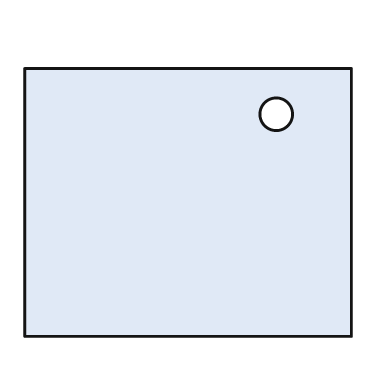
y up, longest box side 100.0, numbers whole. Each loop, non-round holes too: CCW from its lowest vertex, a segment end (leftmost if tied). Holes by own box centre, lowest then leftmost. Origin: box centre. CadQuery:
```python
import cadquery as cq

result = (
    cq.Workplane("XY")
    .moveTo(-50.0, -41.0)
    .lineTo(50.0, -41.0)
    .lineTo(50.0, 41.0)
    .lineTo(-50.0, 41.0)
    .close()
    .moveTo(27.0, 27.0)
    .circle(5.0)
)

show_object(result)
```